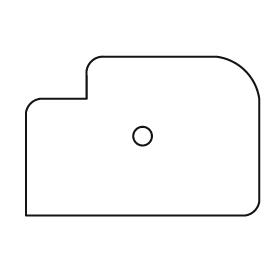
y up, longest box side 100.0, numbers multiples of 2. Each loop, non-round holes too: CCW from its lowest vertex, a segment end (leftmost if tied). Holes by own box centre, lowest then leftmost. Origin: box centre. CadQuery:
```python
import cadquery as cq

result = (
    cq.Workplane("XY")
    .moveTo(-50.0, -34.0)
    .lineTo(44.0, -34.0)
    .threePointArc((48.0, -32.0), (50.0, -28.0))
    .lineTo(50.0, 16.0)
    .threePointArc((44.0, 28.0), (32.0, 34.0))
    .lineTo(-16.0, 34.0)
    .threePointArc((-22.0, 32.0), (-24.0, 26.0))
    .lineTo(-24.0, 16.0)
    .lineTo(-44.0, 16.0)
    .threePointArc((-48.0, 14.0), (-50.0, 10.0))
    .close()
    .moveTo(0.0, 0.0)
    .circle(4.0)
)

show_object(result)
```